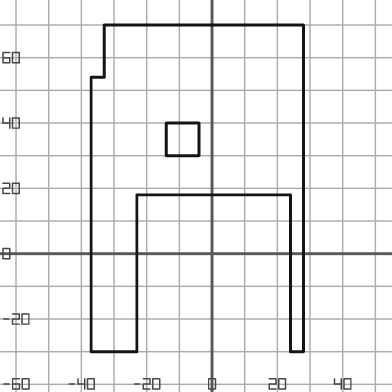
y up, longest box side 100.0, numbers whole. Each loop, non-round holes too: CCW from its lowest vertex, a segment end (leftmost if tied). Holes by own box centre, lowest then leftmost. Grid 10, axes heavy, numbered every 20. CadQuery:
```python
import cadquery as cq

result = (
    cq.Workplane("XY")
    .moveTo(-37.0, -30.0)
    .lineTo(-23.0, -30.0)
    .lineTo(-23.0, 18.0)
    .lineTo(24.0, 18.0)
    .lineTo(24.0, -30.0)
    .lineTo(28.0, -30.0)
    .lineTo(28.0, 70.0)
    .lineTo(-33.0, 70.0)
    .lineTo(-33.0, 54.0)
    .lineTo(-37.0, 54.0)
    .close()
    .moveTo(-14.0, 30.0)
    .lineTo(-4.0, 30.0)
    .lineTo(-4.0, 40.0)
    .lineTo(-14.0, 40.0)
    .close()
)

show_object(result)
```